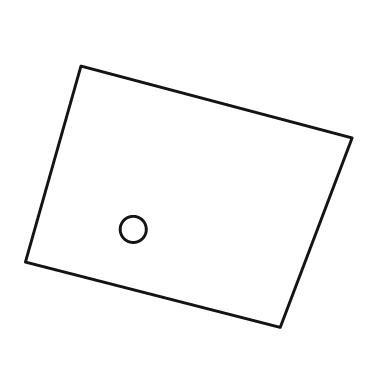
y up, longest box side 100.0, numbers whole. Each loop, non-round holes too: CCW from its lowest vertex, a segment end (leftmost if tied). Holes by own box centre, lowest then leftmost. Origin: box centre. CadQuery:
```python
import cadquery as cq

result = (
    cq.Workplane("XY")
    .moveTo(28.0, -40.0)
    .lineTo(50.0, 18.0)
    .lineTo(-33.0, 40.0)
    .lineTo(-50.0, -20.0)
    .close()
    .moveTo(-17.0, -10.0)
    .circle(4.0)
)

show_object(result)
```